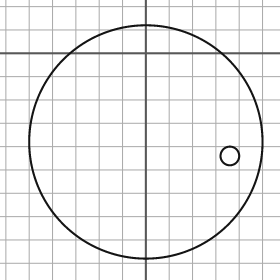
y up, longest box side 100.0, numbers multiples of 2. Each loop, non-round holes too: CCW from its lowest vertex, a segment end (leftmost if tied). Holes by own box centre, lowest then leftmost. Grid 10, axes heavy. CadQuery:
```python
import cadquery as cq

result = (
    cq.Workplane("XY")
    .moveTo(0.0, -38.0)
    .circle(50.0)
    .moveTo(36.0, -44.0)
    .circle(4.0)
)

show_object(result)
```